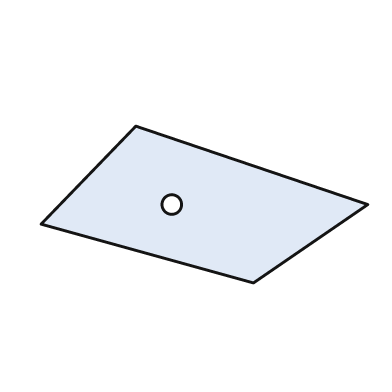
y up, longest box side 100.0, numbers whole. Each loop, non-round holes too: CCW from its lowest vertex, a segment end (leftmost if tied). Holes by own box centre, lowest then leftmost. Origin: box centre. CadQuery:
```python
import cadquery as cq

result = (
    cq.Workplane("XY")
    .moveTo(15.0, -24.0)
    .lineTo(50.0, 0.0)
    .lineTo(-21.0, 24.0)
    .lineTo(-50.0, -6.0)
    .close()
    .moveTo(-10.0, 0.0)
    .circle(3.0)
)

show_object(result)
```